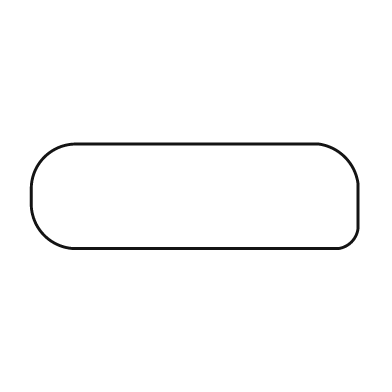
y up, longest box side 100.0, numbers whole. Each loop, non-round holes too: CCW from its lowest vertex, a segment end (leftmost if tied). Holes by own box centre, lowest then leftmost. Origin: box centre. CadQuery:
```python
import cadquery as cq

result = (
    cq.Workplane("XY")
    .moveTo(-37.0, -16.0)
    .lineTo(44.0, -16.0)
    .threePointArc((48.0, -14.0), (50.0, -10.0))
    .lineTo(50.0, 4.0)
    .threePointArc((46.0, 12.0), (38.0, 16.0))
    .lineTo(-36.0, 16.0)
    .threePointArc((-46.0, 12.0), (-50.0, 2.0))
    .lineTo(-50.0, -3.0)
    .threePointArc((-46.0, -12.0), (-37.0, -16.0))
    .close()
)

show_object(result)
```